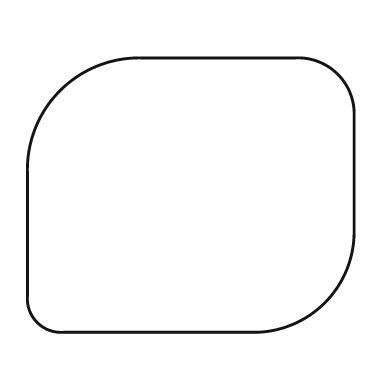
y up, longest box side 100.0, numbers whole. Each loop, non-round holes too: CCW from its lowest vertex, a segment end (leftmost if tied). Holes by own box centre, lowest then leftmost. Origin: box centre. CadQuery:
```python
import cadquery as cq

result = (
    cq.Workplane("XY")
    .moveTo(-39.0, -42.0)
    .lineTo(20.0, -42.0)
    .threePointArc((41.0, -33.0), (50.0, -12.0))
    .lineTo(50.0, 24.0)
    .threePointArc((45.0, 37.0), (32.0, 42.0))
    .lineTo(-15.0, 42.0)
    .threePointArc((-40.0, 32.0), (-50.0, 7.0))
    .lineTo(-50.0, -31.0)
    .threePointArc((-47.0, -39.0), (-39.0, -42.0))
    .close()
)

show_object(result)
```